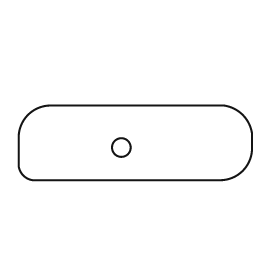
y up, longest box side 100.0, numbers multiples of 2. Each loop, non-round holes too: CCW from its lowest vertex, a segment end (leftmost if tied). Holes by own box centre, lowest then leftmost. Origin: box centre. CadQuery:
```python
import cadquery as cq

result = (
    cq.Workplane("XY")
    .moveTo(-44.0, -16.0)
    .lineTo(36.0, -16.0)
    .threePointArc((46.0, -12.0), (50.0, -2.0))
    .lineTo(50.0, 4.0)
    .threePointArc((46.0, 12.0), (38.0, 16.0))
    .lineTo(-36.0, 16.0)
    .threePointArc((-46.0, 12.0), (-50.0, 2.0))
    .lineTo(-50.0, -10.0)
    .threePointArc((-48.0, -14.0), (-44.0, -16.0))
    .close()
    .moveTo(-6.0, -2.0)
    .circle(4.0)
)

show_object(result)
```